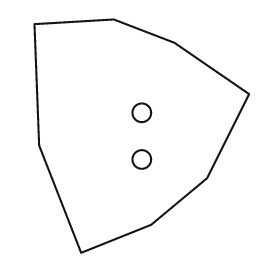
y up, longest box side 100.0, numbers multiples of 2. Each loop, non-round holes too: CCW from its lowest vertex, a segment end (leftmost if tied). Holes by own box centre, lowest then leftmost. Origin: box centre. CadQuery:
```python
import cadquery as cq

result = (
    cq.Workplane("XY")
    .moveTo(-26.0, -50.0)
    .lineTo(4.0, -38.0)
    .lineTo(28.0, -18.0)
    .lineTo(46.0, 18.0)
    .lineTo(14.0, 40.0)
    .lineTo(-12.0, 50.0)
    .lineTo(-46.0, 48.0)
    .lineTo(-44.0, -4.0)
    .close()
    .moveTo(0.0, -10.0)
    .circle(4.0)
    .moveTo(0.0, 10.0)
    .circle(4.0)
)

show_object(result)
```